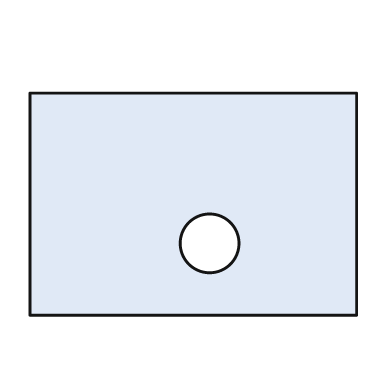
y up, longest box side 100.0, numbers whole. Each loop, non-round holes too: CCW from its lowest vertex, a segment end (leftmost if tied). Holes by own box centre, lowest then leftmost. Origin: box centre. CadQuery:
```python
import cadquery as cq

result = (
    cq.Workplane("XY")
    .moveTo(-50.0, -34.0)
    .lineTo(50.0, -34.0)
    .lineTo(50.0, 34.0)
    .lineTo(-50.0, 34.0)
    .close()
    .moveTo(5.0, -12.0)
    .circle(9.0)
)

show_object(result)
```